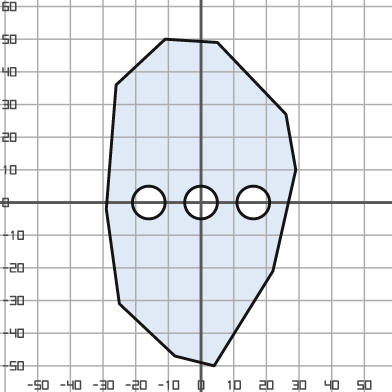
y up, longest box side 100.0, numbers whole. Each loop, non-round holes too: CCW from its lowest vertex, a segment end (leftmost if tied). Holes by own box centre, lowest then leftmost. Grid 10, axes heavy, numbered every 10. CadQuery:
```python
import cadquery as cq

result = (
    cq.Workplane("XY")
    .moveTo(4.0, -50.0)
    .lineTo(22.0, -21.0)
    .lineTo(29.0, 10.0)
    .lineTo(26.0, 27.0)
    .lineTo(5.0, 49.0)
    .lineTo(-11.0, 50.0)
    .lineTo(-26.0, 36.0)
    .lineTo(-29.0, -2.0)
    .lineTo(-25.0, -31.0)
    .lineTo(-8.0, -47.0)
    .close()
    .moveTo(-16.0, 0.0)
    .circle(5.0)
    .moveTo(0.0, 0.0)
    .circle(5.0)
    .moveTo(16.0, 0.0)
    .circle(5.0)
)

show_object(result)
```